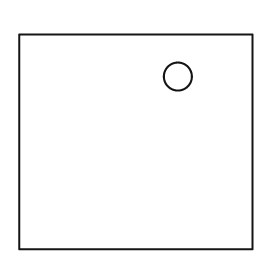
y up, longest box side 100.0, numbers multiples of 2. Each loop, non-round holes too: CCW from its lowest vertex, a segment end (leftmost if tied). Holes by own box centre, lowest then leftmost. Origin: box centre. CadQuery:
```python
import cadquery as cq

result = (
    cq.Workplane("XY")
    .moveTo(-50.0, -46.0)
    .lineTo(50.0, -46.0)
    .lineTo(50.0, 46.0)
    .lineTo(-50.0, 46.0)
    .close()
    .moveTo(18.0, 28.0)
    .circle(6.0)
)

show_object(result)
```